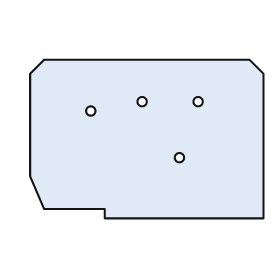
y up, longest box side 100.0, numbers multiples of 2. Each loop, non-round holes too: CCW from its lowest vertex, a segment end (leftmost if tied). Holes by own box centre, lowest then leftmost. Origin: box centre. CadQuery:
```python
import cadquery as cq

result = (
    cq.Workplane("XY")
    .moveTo(-18.0, -34.0)
    .lineTo(50.0, -34.0)
    .lineTo(50.0, 28.0)
    .lineTo(44.0, 34.0)
    .lineTo(-44.0, 34.0)
    .lineTo(-50.0, 28.0)
    .lineTo(-50.0, -16.0)
    .lineTo(-44.0, -30.0)
    .lineTo(-18.0, -30.0)
    .close()
    .moveTo(14.0, -8.0)
    .circle(2.0)
    .moveTo(-24.0, 12.0)
    .circle(2.0)
    .moveTo(-2.0, 16.0)
    .circle(2.0)
    .moveTo(22.0, 16.0)
    .circle(2.0)
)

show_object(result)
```